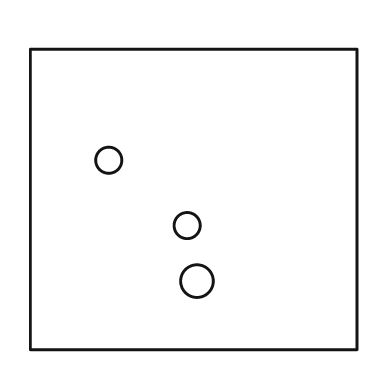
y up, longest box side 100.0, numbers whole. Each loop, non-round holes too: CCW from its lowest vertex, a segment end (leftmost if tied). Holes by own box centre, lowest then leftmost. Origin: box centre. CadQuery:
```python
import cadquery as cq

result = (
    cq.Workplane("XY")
    .moveTo(-50.0, -46.0)
    .lineTo(50.0, -46.0)
    .lineTo(50.0, 46.0)
    .lineTo(-50.0, 46.0)
    .close()
    .moveTo(1.0, -25.0)
    .circle(5.0)
    .moveTo(-2.0, -8.0)
    .circle(4.0)
    .moveTo(-26.0, 12.0)
    .circle(4.0)
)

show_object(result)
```